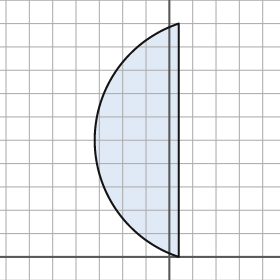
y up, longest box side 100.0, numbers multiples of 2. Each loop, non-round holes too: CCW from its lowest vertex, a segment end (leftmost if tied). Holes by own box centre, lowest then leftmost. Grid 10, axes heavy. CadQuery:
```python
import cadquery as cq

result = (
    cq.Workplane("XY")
    .moveTo(4.0, 0.0)
    .lineTo(4.0, 100.0)
    .threePointArc((-32.0, 50.0), (4.0, 0.0))
    .close()
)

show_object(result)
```